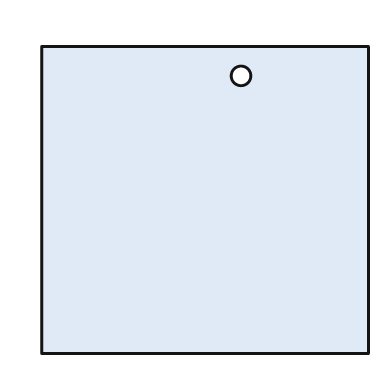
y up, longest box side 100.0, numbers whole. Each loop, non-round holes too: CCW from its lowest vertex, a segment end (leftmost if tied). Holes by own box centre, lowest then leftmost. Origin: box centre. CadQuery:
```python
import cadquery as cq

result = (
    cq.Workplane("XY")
    .moveTo(-50.0, -47.0)
    .lineTo(50.0, -47.0)
    .lineTo(50.0, 47.0)
    .lineTo(-50.0, 47.0)
    .close()
    .moveTo(11.0, 38.0)
    .circle(3.0)
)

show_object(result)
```